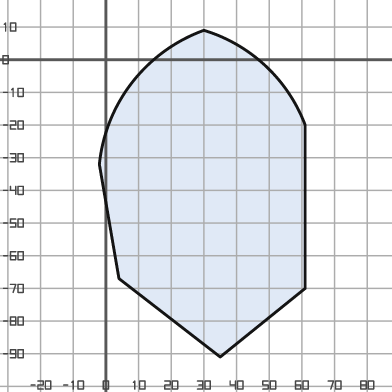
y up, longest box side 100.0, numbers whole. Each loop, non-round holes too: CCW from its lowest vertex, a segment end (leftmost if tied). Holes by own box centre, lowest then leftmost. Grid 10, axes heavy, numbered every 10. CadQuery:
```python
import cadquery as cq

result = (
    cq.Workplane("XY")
    .moveTo(35.0, -91.0)
    .lineTo(61.0, -70.0)
    .lineTo(61.0, -20.0)
    .threePointArc((49.0, -2.0), (30.0, 9.0))
    .threePointArc((8.0, -7.0), (-2.0, -32.0))
    .lineTo(4.0, -67.0)
    .close()
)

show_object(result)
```